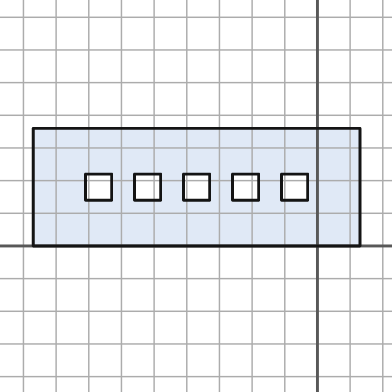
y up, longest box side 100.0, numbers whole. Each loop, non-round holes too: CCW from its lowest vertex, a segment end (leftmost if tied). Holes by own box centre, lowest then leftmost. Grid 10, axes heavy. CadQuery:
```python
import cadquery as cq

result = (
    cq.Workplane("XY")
    .moveTo(-87.0, 0.0)
    .lineTo(13.0, 0.0)
    .lineTo(13.0, 36.0)
    .lineTo(-87.0, 36.0)
    .close()
    .moveTo(-71.0, 14.0)
    .lineTo(-63.0, 14.0)
    .lineTo(-63.0, 22.0)
    .lineTo(-71.0, 22.0)
    .close()
    .moveTo(-56.0, 14.0)
    .lineTo(-48.0, 14.0)
    .lineTo(-48.0, 22.0)
    .lineTo(-56.0, 22.0)
    .close()
    .moveTo(-41.0, 14.0)
    .lineTo(-33.0, 14.0)
    .lineTo(-33.0, 22.0)
    .lineTo(-41.0, 22.0)
    .close()
    .moveTo(-26.0, 14.0)
    .lineTo(-18.0, 14.0)
    .lineTo(-18.0, 22.0)
    .lineTo(-26.0, 22.0)
    .close()
    .moveTo(-11.0, 14.0)
    .lineTo(-3.0, 14.0)
    .lineTo(-3.0, 22.0)
    .lineTo(-11.0, 22.0)
    .close()
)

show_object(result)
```